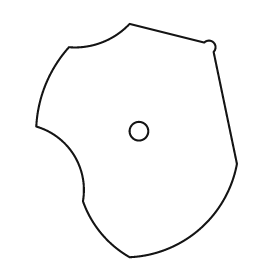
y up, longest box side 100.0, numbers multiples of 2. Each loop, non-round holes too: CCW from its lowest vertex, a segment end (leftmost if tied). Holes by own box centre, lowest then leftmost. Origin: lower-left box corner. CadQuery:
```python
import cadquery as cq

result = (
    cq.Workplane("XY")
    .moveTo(40.0, 0.0)
    .threePointArc((70.0, 12.0), (86.0, 40.0))
    .lineTo(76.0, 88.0)
    .threePointArc((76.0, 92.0), (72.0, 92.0))
    .lineTo(40.0, 100.0)
    .threePointArc((28.0, 92.0), (14.0, 90.0))
    .threePointArc((4.0, 74.0), (0.0, 56.0))
    .threePointArc((16.0, 44.0), (20.0, 24.0))
    .threePointArc((28.0, 10.0), (40.0, 0.0))
    .close()
    .moveTo(44.0, 54.0)
    .circle(4.0)
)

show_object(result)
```